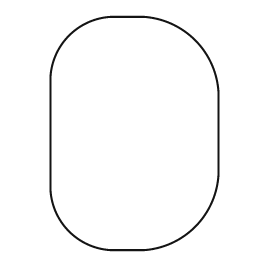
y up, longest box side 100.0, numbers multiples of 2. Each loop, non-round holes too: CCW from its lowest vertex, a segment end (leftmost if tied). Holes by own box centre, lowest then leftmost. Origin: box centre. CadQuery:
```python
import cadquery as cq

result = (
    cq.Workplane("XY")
    .moveTo(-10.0, -50.0)
    .lineTo(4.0, -50.0)
    .threePointArc((26.0, -40.0), (36.0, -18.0))
    .lineTo(36.0, 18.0)
    .threePointArc((26.0, 40.0), (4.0, 50.0))
    .lineTo(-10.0, 50.0)
    .threePointArc((-28.0, 42.0), (-36.0, 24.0))
    .lineTo(-36.0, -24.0)
    .threePointArc((-28.0, -42.0), (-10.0, -50.0))
    .close()
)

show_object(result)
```